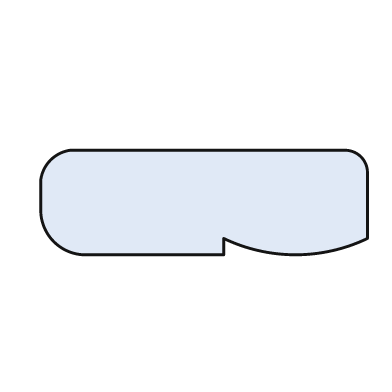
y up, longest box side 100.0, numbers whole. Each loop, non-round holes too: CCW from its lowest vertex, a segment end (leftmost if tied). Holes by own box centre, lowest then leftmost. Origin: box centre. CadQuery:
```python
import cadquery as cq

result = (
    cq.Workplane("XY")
    .moveTo(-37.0, -16.0)
    .lineTo(6.0, -16.0)
    .lineTo(6.0, -11.0)
    .threePointArc((28.0, -16.0), (50.0, -11.0))
    .lineTo(50.0, 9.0)
    .threePointArc((48.0, 14.0), (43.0, 16.0))
    .lineTo(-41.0, 16.0)
    .threePointArc((-47.0, 13.0), (-50.0, 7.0))
    .lineTo(-50.0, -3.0)
    .threePointArc((-46.0, -12.0), (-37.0, -16.0))
    .close()
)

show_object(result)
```